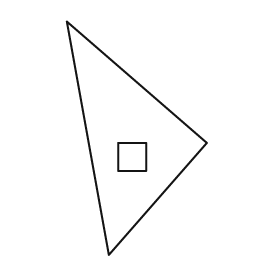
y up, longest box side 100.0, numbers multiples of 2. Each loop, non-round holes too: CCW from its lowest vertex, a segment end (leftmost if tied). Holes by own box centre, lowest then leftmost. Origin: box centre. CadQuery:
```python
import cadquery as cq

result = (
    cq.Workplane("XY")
    .moveTo(-12.0, -50.0)
    .lineTo(30.0, -2.0)
    .lineTo(-30.0, 50.0)
    .close()
    .moveTo(-8.0, -14.0)
    .lineTo(4.0, -14.0)
    .lineTo(4.0, -2.0)
    .lineTo(-8.0, -2.0)
    .close()
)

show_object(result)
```